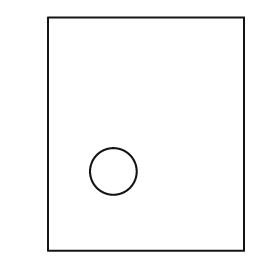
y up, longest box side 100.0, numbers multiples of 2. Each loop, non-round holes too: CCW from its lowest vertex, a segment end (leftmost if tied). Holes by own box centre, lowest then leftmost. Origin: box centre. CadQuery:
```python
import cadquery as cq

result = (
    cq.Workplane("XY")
    .moveTo(-42.0, -50.0)
    .lineTo(42.0, -50.0)
    .lineTo(42.0, 50.0)
    .lineTo(-42.0, 50.0)
    .close()
    .moveTo(-14.0, -16.0)
    .circle(10.0)
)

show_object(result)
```